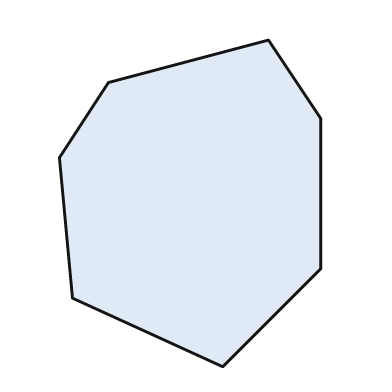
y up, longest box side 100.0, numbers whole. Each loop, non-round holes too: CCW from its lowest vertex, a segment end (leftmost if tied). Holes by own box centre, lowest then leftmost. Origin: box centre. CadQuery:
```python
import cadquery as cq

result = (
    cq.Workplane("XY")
    .moveTo(10.0, -50.0)
    .lineTo(40.0, -20.0)
    .lineTo(40.0, 26.0)
    .lineTo(24.0, 50.0)
    .lineTo(-25.0, 37.0)
    .lineTo(-40.0, 14.0)
    .lineTo(-36.0, -29.0)
    .close()
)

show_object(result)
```